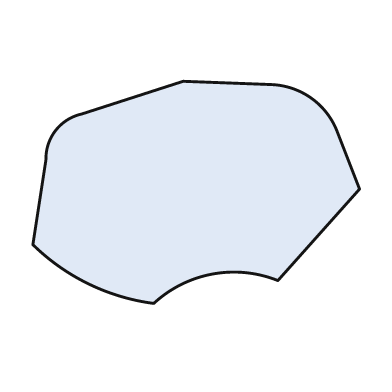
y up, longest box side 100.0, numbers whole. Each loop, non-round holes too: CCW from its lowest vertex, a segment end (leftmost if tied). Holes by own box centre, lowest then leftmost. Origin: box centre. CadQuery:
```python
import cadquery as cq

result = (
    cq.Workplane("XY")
    .moveTo(-13.0, -34.0)
    .threePointArc((5.0, -25.0), (25.0, -27.0))
    .lineTo(50.0, 1.0)
    .lineTo(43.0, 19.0)
    .threePointArc((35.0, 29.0), (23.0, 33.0))
    .lineTo(-4.0, 34.0)
    .lineTo(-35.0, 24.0)
    .threePointArc((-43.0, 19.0), (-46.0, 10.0))
    .lineTo(-50.0, -16.0)
    .threePointArc((-33.0, -28.0), (-13.0, -34.0))
    .close()
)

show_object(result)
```